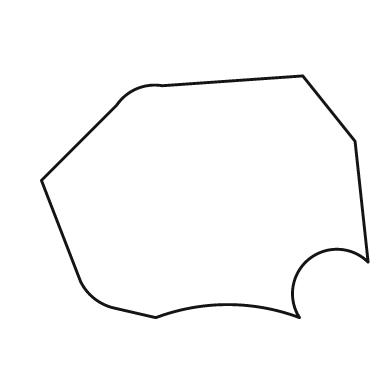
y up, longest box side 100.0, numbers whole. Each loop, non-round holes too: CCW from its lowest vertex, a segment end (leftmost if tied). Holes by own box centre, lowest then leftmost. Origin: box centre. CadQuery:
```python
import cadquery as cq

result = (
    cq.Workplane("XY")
    .moveTo(-15.0, -37.0)
    .threePointArc((7.0, -33.0), (29.0, -37.0))
    .threePointArc((32.0, -19.0), (50.0, -20.0))
    .lineTo(46.0, 17.0)
    .lineTo(30.0, 37.0)
    .lineTo(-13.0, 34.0)
    .threePointArc((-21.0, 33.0), (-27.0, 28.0))
    .lineTo(-50.0, 5.0)
    .lineTo(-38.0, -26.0)
    .threePointArc((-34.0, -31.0), (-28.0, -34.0))
    .close()
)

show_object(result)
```